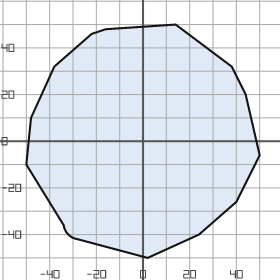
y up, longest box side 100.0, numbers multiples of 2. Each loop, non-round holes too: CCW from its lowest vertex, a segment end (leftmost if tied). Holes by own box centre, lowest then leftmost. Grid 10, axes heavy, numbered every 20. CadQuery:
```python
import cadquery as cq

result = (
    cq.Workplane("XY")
    .moveTo(2.0, -50.0)
    .lineTo(24.0, -40.0)
    .lineTo(40.0, -26.0)
    .lineTo(50.0, -6.0)
    .lineTo(44.0, 20.0)
    .lineTo(38.0, 32.0)
    .lineTo(14.0, 50.0)
    .lineTo(-16.0, 48.0)
    .lineTo(-22.0, 46.0)
    .lineTo(-38.0, 32.0)
    .lineTo(-48.0, 10.0)
    .lineTo(-50.0, -10.0)
    .lineTo(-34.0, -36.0)
    .threePointArc((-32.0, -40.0), (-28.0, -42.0))
    .close()
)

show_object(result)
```